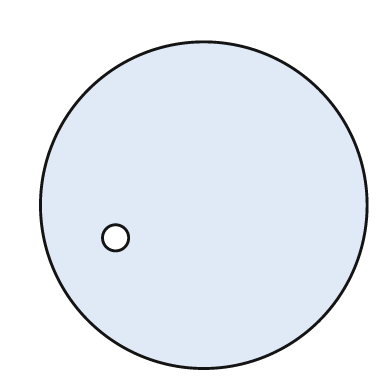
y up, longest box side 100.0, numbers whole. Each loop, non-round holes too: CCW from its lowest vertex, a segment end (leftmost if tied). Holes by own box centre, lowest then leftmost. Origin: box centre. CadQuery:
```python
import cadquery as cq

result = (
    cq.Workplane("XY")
    .moveTo(0.0, 0.0)
    .circle(50.0)
    .moveTo(-27.0, -10.0)
    .circle(4.0)
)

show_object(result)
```